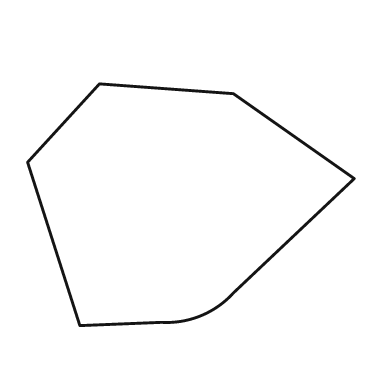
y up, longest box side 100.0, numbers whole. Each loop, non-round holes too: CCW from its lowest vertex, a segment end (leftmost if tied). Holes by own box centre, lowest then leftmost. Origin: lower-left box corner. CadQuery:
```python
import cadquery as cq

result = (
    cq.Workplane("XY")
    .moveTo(16.0, 0.0)
    .lineTo(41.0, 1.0)
    .threePointArc((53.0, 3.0), (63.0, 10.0))
    .lineTo(100.0, 45.0)
    .lineTo(63.0, 71.0)
    .lineTo(22.0, 74.0)
    .lineTo(0.0, 50.0)
    .close()
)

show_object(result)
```